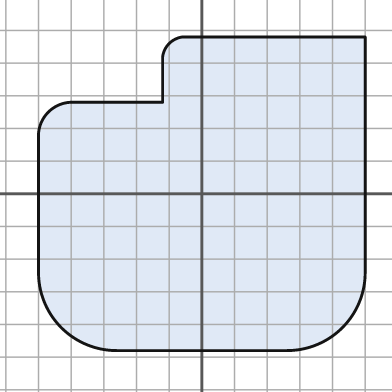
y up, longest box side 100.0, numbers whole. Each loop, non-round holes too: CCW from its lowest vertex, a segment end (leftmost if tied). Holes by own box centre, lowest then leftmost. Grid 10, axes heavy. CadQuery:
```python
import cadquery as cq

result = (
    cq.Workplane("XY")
    .moveTo(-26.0, -48.0)
    .lineTo(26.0, -48.0)
    .threePointArc((43.0, -41.0), (50.0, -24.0))
    .lineTo(50.0, 48.0)
    .lineTo(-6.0, 48.0)
    .threePointArc((-10.0, 46.0), (-12.0, 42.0))
    .lineTo(-12.0, 28.0)
    .lineTo(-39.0, 28.0)
    .threePointArc((-47.0, 25.0), (-50.0, 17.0))
    .lineTo(-50.0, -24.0)
    .threePointArc((-43.0, -41.0), (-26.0, -48.0))
    .close()
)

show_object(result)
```